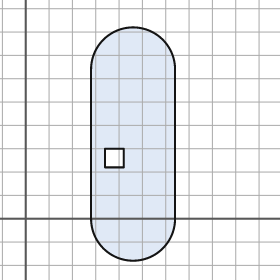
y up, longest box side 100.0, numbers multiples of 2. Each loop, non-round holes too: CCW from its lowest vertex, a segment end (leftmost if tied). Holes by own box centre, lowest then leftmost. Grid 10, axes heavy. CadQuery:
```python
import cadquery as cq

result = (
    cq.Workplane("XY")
    .moveTo(28.0, 0.0)
    .threePointArc((46.0, -18.0), (64.0, 0.0))
    .lineTo(64.0, 64.0)
    .threePointArc((46.0, 82.0), (28.0, 64.0))
    .close()
    .moveTo(34.0, 22.0)
    .lineTo(42.0, 22.0)
    .lineTo(42.0, 30.0)
    .lineTo(34.0, 30.0)
    .close()
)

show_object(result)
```